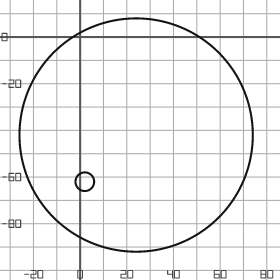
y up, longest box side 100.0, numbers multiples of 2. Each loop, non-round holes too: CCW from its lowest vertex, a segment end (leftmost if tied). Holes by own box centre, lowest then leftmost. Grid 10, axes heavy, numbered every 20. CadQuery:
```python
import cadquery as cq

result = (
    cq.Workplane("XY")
    .moveTo(24.0, -42.0)
    .circle(50.0)
    .moveTo(2.0, -62.0)
    .circle(4.0)
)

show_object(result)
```